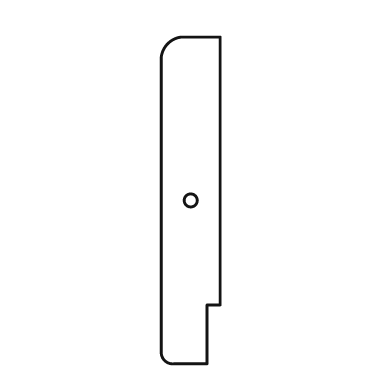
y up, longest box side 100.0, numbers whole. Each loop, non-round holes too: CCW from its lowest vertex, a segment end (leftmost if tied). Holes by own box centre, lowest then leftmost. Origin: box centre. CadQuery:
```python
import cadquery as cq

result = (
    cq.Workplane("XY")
    .moveTo(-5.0, -50.0)
    .lineTo(5.0, -50.0)
    .lineTo(5.0, -32.0)
    .lineTo(9.0, -32.0)
    .lineTo(9.0, 50.0)
    .lineTo(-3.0, 50.0)
    .threePointArc((-7.0, 48.0), (-9.0, 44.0))
    .lineTo(-9.0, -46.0)
    .threePointArc((-8.0, -49.0), (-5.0, -50.0))
    .close()
    .moveTo(0.0, 0.0)
    .circle(2.0)
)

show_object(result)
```